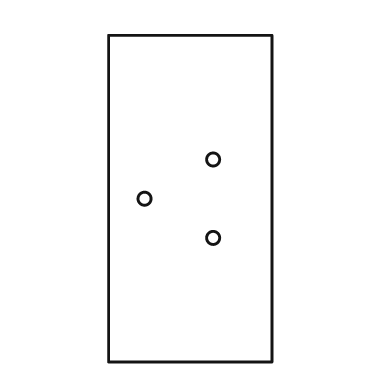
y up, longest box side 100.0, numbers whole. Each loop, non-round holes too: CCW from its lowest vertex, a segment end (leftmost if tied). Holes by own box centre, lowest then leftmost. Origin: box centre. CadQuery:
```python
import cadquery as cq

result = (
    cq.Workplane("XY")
    .moveTo(-25.0, -50.0)
    .lineTo(25.0, -50.0)
    .lineTo(25.0, 50.0)
    .lineTo(-25.0, 50.0)
    .close()
    .moveTo(7.0, -12.0)
    .circle(2.0)
    .moveTo(-14.0, 0.0)
    .circle(2.0)
    .moveTo(7.0, 12.0)
    .circle(2.0)
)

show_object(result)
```